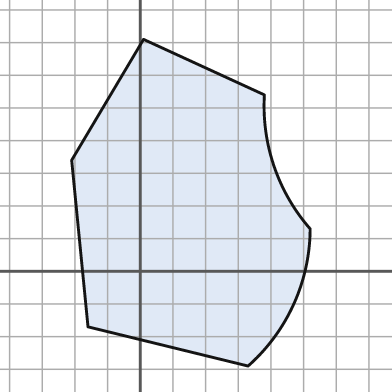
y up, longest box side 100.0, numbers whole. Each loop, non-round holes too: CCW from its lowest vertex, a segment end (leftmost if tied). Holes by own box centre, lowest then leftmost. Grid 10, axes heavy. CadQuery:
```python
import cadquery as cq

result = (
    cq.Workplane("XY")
    .moveTo(33.0, -29.0)
    .threePointArc((47.0, -10.0), (52.0, 13.0))
    .threePointArc((41.0, 32.0), (38.0, 54.0))
    .lineTo(1.0, 71.0)
    .lineTo(-21.0, 34.0)
    .lineTo(-16.0, -17.0)
    .close()
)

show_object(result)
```